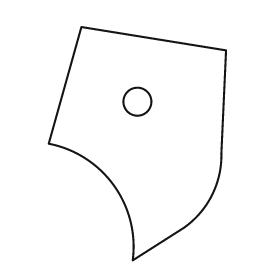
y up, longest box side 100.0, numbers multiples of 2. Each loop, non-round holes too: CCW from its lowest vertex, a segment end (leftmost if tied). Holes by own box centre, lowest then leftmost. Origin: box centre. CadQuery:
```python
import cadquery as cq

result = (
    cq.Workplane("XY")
    .moveTo(-2.0, -50.0)
    .lineTo(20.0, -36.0)
    .threePointArc((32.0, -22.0), (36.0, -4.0))
    .lineTo(38.0, 40.0)
    .lineTo(-24.0, 50.0)
    .lineTo(-38.0, 0.0)
    .threePointArc((-10.0, -18.0), (-2.0, -50.0))
    .close()
    .moveTo(0.0, 18.0)
    .circle(6.0)
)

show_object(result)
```